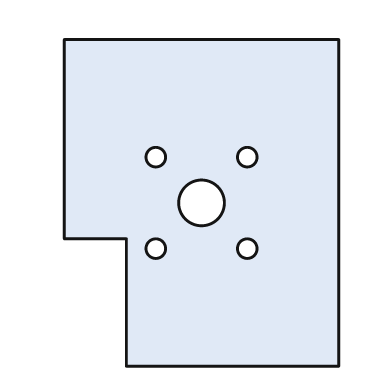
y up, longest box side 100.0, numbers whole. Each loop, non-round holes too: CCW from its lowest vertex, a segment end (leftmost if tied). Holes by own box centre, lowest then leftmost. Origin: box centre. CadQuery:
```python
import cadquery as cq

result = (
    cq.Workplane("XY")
    .moveTo(-23.0, -50.0)
    .lineTo(42.0, -50.0)
    .lineTo(42.0, 50.0)
    .lineTo(-42.0, 50.0)
    .lineTo(-42.0, -11.0)
    .lineTo(-23.0, -11.0)
    .close()
    .moveTo(-14.0, -14.0)
    .circle(3.0)
    .moveTo(14.0, -14.0)
    .circle(3.0)
    .moveTo(0.0, 0.0)
    .circle(7.0)
    .moveTo(-14.0, 14.0)
    .circle(3.0)
    .moveTo(14.0, 14.0)
    .circle(3.0)
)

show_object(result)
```